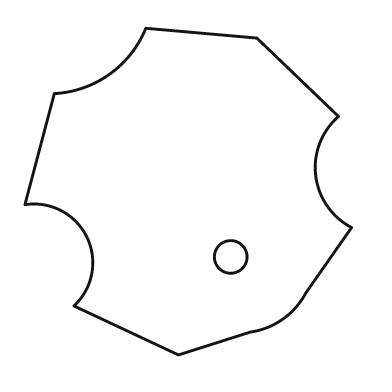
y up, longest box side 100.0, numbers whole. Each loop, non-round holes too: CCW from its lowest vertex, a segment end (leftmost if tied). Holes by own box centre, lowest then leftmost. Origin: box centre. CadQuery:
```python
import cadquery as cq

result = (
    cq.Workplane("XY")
    .moveTo(-3.0, -50.0)
    .lineTo(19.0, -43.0)
    .threePointArc((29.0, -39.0), (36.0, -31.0))
    .lineTo(50.0, -11.0)
    .threePointArc((39.0, 5.0), (46.0, 23.0))
    .lineTo(21.0, 47.0)
    .lineTo(-13.0, 50.0)
    .threePointArc((-24.0, 36.0), (-41.0, 30.0))
    .lineTo(-50.0, -4.0)
    .threePointArc((-31.0, -14.0), (-35.0, -35.0))
    .close()
    .moveTo(13.0, -20.0)
    .circle(5.0)
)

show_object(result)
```